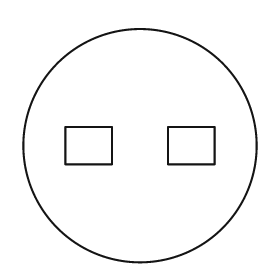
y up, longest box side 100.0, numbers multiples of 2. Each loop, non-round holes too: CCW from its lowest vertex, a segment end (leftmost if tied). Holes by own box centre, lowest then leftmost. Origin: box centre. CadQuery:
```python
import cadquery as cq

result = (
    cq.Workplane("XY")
    .moveTo(0.0, 0.0)
    .circle(50.0)
    .moveTo(-32.0, -8.0)
    .lineTo(-12.0, -8.0)
    .lineTo(-12.0, 8.0)
    .lineTo(-32.0, 8.0)
    .close()
    .moveTo(12.0, -8.0)
    .lineTo(32.0, -8.0)
    .lineTo(32.0, 8.0)
    .lineTo(12.0, 8.0)
    .close()
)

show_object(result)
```